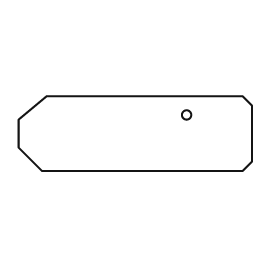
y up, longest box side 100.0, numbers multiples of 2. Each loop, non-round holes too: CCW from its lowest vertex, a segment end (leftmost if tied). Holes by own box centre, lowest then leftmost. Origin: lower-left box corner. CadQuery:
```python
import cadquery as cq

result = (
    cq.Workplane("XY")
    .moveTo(10.0, 0.0)
    .lineTo(96.0, 0.0)
    .lineTo(100.0, 4.0)
    .lineTo(100.0, 28.0)
    .lineTo(96.0, 32.0)
    .lineTo(12.0, 32.0)
    .lineTo(0.0, 22.0)
    .lineTo(0.0, 10.0)
    .close()
    .moveTo(72.0, 24.0)
    .circle(2.0)
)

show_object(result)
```